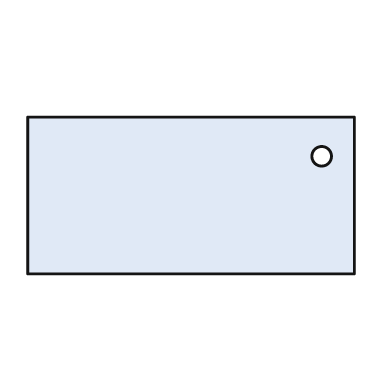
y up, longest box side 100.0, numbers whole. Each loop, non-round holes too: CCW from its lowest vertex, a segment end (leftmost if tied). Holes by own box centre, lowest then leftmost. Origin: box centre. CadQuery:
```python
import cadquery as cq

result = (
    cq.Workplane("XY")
    .moveTo(-50.0, -24.0)
    .lineTo(50.0, -24.0)
    .lineTo(50.0, 24.0)
    .lineTo(-50.0, 24.0)
    .close()
    .moveTo(40.0, 12.0)
    .circle(3.0)
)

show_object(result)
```